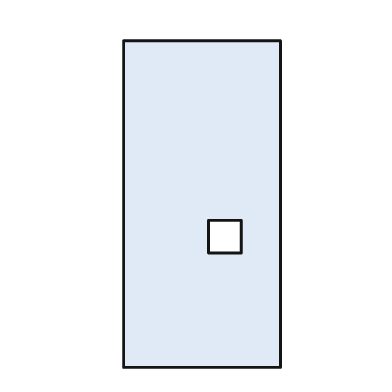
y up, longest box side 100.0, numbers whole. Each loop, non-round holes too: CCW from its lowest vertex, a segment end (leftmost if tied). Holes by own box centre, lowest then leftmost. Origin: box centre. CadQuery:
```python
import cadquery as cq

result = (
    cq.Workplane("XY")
    .moveTo(-24.0, -50.0)
    .lineTo(24.0, -50.0)
    .lineTo(24.0, 50.0)
    .lineTo(-24.0, 50.0)
    .close()
    .moveTo(2.0, -15.0)
    .lineTo(12.0, -15.0)
    .lineTo(12.0, -5.0)
    .lineTo(2.0, -5.0)
    .close()
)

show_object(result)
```